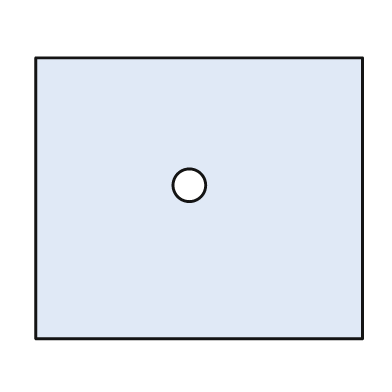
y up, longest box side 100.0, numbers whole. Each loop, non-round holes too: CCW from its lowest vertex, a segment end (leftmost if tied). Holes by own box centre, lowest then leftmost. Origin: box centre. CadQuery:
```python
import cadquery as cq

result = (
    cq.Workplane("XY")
    .moveTo(-50.0, -43.0)
    .lineTo(50.0, -43.0)
    .lineTo(50.0, 43.0)
    .lineTo(-50.0, 43.0)
    .close()
    .moveTo(-3.0, 4.0)
    .circle(5.0)
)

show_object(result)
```